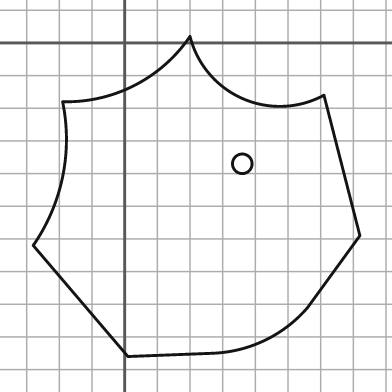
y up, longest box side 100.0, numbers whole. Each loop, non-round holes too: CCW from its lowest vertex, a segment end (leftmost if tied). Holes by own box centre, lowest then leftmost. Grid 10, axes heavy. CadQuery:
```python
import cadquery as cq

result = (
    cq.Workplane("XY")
    .moveTo(1.0, -96.0)
    .lineTo(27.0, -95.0)
    .threePointArc((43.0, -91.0), (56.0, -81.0))
    .lineTo(72.0, -59.0)
    .lineTo(61.0, -16.0)
    .threePointArc((36.0, -17.0), (20.0, 2.0))
    .threePointArc((3.0, -13.0), (-19.0, -18.0))
    .threePointArc((-19.0, -41.0), (-28.0, -62.0))
    .close()
    .moveTo(36.0, -37.0)
    .circle(3.0)
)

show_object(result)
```